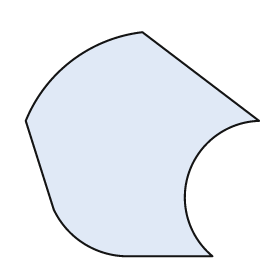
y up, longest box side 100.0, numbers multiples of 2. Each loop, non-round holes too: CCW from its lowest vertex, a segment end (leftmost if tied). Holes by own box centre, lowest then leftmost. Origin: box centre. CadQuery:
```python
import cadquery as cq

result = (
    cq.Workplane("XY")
    .moveTo(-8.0, -48.0)
    .lineTo(30.0, -48.0)
    .threePointArc((20.0, -12.0), (50.0, 10.0))
    .lineTo(0.0, 48.0)
    .threePointArc((-30.0, 36.0), (-50.0, 10.0))
    .lineTo(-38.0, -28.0)
    .threePointArc((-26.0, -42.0), (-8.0, -48.0))
    .close()
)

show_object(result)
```